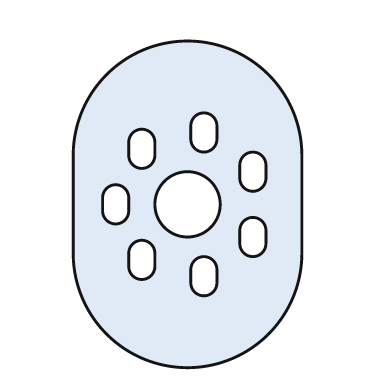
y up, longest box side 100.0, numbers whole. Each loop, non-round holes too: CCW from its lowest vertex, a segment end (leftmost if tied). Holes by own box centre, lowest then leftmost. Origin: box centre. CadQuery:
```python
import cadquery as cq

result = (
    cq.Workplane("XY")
    .moveTo(-35.0, -15.0)
    .threePointArc((0.0, -50.0), (35.0, -15.0))
    .lineTo(35.0, 15.0)
    .threePointArc((0.0, 50.0), (-35.0, 15.0))
    .close()
    .moveTo(1.0, -24.0)
    .threePointArc((5.0, -28.0), (9.0, -24.0))
    .lineTo(9.0, -20.0)
    .threePointArc((5.0, -16.0), (1.0, -20.0))
    .close()
    .moveTo(-18.0, -19.0)
    .threePointArc((-14.0, -23.0), (-10.0, -19.0))
    .lineTo(-10.0, -15.0)
    .threePointArc((-14.0, -11.0), (-18.0, -15.0))
    .close()
    .moveTo(16.0, -12.0)
    .threePointArc((20.0, -16.0), (24.0, -12.0))
    .lineTo(24.0, -8.0)
    .threePointArc((20.0, -4.0), (16.0, -8.0))
    .close()
    .moveTo(-26.0, -2.0)
    .threePointArc((-22.0, -6.0), (-18.0, -2.0))
    .lineTo(-18.0, 2.0)
    .threePointArc((-22.0, 6.0), (-26.0, 2.0))
    .close()
    .moveTo(0.0, 0.0)
    .circle(10.0)
    .moveTo(16.0, 8.0)
    .threePointArc((20.0, 4.0), (24.0, 8.0))
    .lineTo(24.0, 12.0)
    .threePointArc((20.0, 16.0), (16.0, 12.0))
    .close()
    .moveTo(-18.0, 15.0)
    .threePointArc((-14.0, 11.0), (-10.0, 15.0))
    .lineTo(-10.0, 19.0)
    .threePointArc((-14.0, 23.0), (-18.0, 19.0))
    .close()
    .moveTo(1.0, 20.0)
    .threePointArc((5.0, 16.0), (9.0, 20.0))
    .lineTo(9.0, 24.0)
    .threePointArc((5.0, 28.0), (1.0, 24.0))
    .close()
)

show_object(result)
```